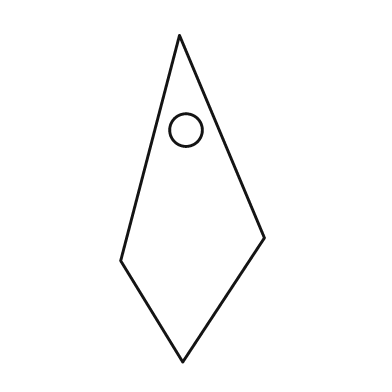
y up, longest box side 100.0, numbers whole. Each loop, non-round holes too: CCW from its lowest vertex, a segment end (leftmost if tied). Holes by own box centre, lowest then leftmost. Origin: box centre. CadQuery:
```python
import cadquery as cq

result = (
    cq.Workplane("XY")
    .moveTo(-3.0, -50.0)
    .lineTo(22.0, -12.0)
    .lineTo(-4.0, 50.0)
    .lineTo(-22.0, -19.0)
    .close()
    .moveTo(-2.0, 21.0)
    .circle(5.0)
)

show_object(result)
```